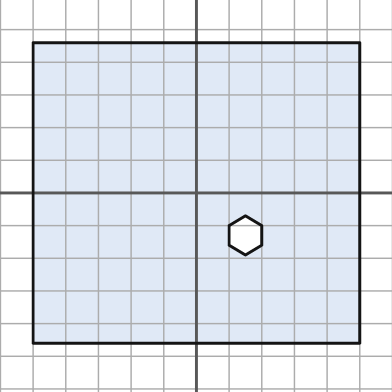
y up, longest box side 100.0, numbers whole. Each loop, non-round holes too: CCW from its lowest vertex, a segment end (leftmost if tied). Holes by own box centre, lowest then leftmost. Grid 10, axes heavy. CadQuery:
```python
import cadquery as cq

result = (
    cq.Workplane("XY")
    .moveTo(-50.0, -46.0)
    .lineTo(50.0, -46.0)
    .lineTo(50.0, 46.0)
    .lineTo(-50.0, 46.0)
    .close()
    .moveTo(15.0, -19.0)
    .lineTo(20.0, -16.0)
    .lineTo(20.0, -10.0)
    .lineTo(15.0, -7.0)
    .lineTo(10.0, -10.0)
    .lineTo(10.0, -16.0)
    .close()
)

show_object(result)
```